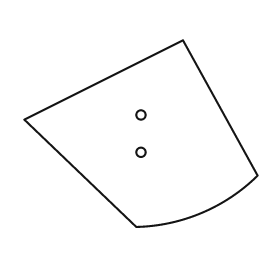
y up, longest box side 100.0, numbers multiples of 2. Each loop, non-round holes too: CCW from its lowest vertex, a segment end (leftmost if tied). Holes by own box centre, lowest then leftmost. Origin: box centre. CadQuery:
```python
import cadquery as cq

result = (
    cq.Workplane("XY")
    .moveTo(-2.0, -40.0)
    .threePointArc((26.0, -34.0), (50.0, -18.0))
    .lineTo(18.0, 40.0)
    .lineTo(-50.0, 6.0)
    .close()
    .moveTo(0.0, -8.0)
    .circle(2.0)
    .moveTo(0.0, 8.0)
    .circle(2.0)
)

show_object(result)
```